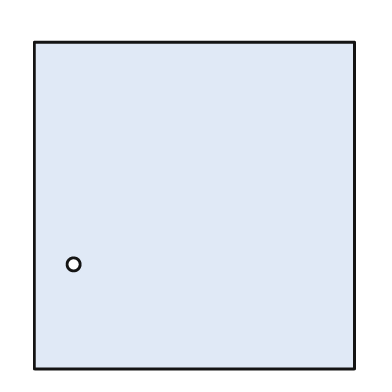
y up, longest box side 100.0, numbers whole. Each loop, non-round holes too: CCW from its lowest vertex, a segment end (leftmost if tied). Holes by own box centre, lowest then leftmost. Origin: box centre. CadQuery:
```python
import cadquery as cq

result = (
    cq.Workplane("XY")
    .moveTo(-49.0, -50.0)
    .lineTo(49.0, -50.0)
    .lineTo(49.0, 50.0)
    .lineTo(-49.0, 50.0)
    .close()
    .moveTo(-37.0, -18.0)
    .circle(2.0)
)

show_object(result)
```